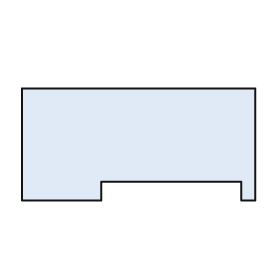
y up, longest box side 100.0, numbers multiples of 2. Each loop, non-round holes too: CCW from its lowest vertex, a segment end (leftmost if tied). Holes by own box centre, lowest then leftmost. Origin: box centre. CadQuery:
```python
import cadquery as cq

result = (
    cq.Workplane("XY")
    .moveTo(-50.0, -24.0)
    .lineTo(-16.0, -24.0)
    .lineTo(-16.0, -16.0)
    .lineTo(44.0, -16.0)
    .lineTo(44.0, -24.0)
    .lineTo(50.0, -24.0)
    .lineTo(50.0, 24.0)
    .lineTo(-50.0, 24.0)
    .close()
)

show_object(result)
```